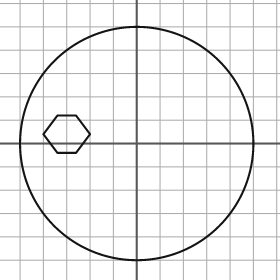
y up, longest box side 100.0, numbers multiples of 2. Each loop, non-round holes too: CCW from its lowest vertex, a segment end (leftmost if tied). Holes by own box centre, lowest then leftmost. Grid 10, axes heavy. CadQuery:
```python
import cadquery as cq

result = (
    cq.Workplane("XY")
    .moveTo(0.0, 0.0)
    .circle(50.0)
    .moveTo(-34.0, -4.0)
    .lineTo(-26.0, -4.0)
    .lineTo(-20.0, 4.0)
    .lineTo(-26.0, 12.0)
    .lineTo(-34.0, 12.0)
    .lineTo(-40.0, 4.0)
    .close()
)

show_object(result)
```